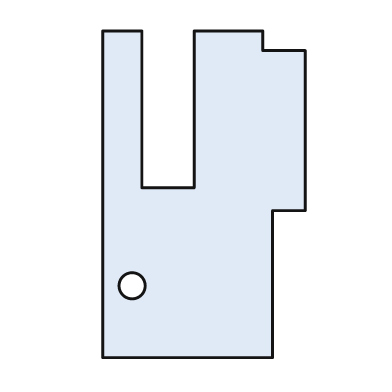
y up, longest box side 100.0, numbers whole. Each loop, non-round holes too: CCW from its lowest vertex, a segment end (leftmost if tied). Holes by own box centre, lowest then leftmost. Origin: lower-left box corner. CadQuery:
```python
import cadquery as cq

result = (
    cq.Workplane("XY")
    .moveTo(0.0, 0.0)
    .lineTo(52.0, 0.0)
    .lineTo(52.0, 45.0)
    .lineTo(62.0, 45.0)
    .lineTo(62.0, 94.0)
    .lineTo(49.0, 94.0)
    .lineTo(49.0, 100.0)
    .lineTo(28.0, 100.0)
    .lineTo(28.0, 52.0)
    .lineTo(12.0, 52.0)
    .lineTo(12.0, 100.0)
    .lineTo(0.0, 100.0)
    .close()
    .moveTo(9.0, 22.0)
    .circle(4.0)
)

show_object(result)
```